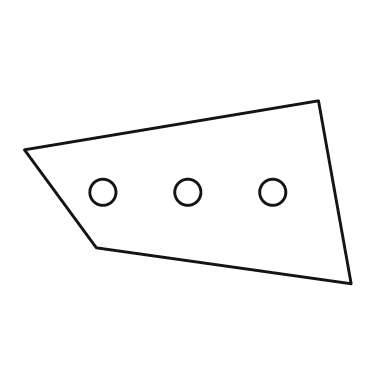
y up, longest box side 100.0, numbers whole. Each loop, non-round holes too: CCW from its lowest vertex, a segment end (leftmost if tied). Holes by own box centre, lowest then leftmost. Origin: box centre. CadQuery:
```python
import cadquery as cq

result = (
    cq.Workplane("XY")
    .moveTo(50.0, -28.0)
    .lineTo(40.0, 28.0)
    .lineTo(-50.0, 13.0)
    .lineTo(-28.0, -17.0)
    .close()
    .moveTo(-26.0, 0.0)
    .circle(4.0)
    .moveTo(0.0, 0.0)
    .circle(4.0)
    .moveTo(26.0, 0.0)
    .circle(4.0)
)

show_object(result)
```